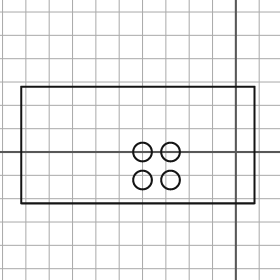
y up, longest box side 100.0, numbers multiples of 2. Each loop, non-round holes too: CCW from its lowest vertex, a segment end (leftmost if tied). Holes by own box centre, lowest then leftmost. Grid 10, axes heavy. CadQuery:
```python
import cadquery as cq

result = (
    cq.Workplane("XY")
    .moveTo(-92.0, -22.0)
    .lineTo(8.0, -22.0)
    .lineTo(8.0, 28.0)
    .lineTo(-92.0, 28.0)
    .close()
    .moveTo(-40.0, -12.0)
    .circle(4.0)
    .moveTo(-28.0, -12.0)
    .circle(4.0)
    .moveTo(-40.0, 0.0)
    .circle(4.0)
    .moveTo(-28.0, 0.0)
    .circle(4.0)
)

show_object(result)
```